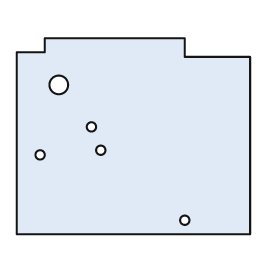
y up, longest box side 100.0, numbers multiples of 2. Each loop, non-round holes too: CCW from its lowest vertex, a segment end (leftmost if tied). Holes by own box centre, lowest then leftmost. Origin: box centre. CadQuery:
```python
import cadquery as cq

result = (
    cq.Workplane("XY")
    .moveTo(-50.0, -42.0)
    .lineTo(50.0, -42.0)
    .lineTo(50.0, 34.0)
    .lineTo(22.0, 34.0)
    .lineTo(22.0, 42.0)
    .lineTo(-38.0, 42.0)
    .lineTo(-38.0, 36.0)
    .lineTo(-50.0, 36.0)
    .close()
    .moveTo(22.0, -36.0)
    .circle(2.0)
    .moveTo(-40.0, -8.0)
    .circle(2.0)
    .moveTo(-14.0, -6.0)
    .circle(2.0)
    .moveTo(-18.0, 4.0)
    .circle(2.0)
    .moveTo(-32.0, 22.0)
    .circle(4.0)
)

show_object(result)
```